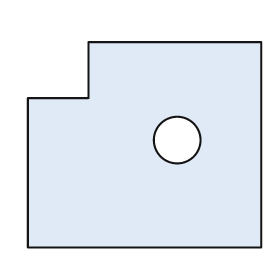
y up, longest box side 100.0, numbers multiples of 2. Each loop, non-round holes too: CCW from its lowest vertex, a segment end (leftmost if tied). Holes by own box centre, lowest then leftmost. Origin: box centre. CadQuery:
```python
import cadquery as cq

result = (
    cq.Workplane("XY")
    .moveTo(-50.0, -44.0)
    .lineTo(50.0, -44.0)
    .lineTo(50.0, 44.0)
    .lineTo(-24.0, 44.0)
    .lineTo(-24.0, 20.0)
    .lineTo(-50.0, 20.0)
    .close()
    .moveTo(14.0, 2.0)
    .circle(10.0)
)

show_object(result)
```